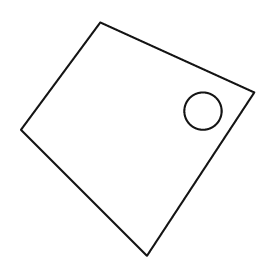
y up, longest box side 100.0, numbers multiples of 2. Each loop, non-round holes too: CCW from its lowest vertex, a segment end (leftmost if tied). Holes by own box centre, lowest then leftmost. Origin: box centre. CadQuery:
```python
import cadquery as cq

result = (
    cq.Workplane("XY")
    .moveTo(4.0, -50.0)
    .lineTo(50.0, 20.0)
    .lineTo(-16.0, 50.0)
    .lineTo(-50.0, 4.0)
    .close()
    .moveTo(28.0, 12.0)
    .circle(8.0)
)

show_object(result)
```